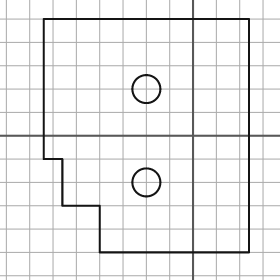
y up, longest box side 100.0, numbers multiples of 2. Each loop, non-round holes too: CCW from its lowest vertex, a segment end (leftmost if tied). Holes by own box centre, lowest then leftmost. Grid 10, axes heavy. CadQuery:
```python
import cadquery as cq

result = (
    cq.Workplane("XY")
    .moveTo(-40.0, -50.0)
    .lineTo(24.0, -50.0)
    .lineTo(24.0, 50.0)
    .lineTo(-64.0, 50.0)
    .lineTo(-64.0, -10.0)
    .lineTo(-56.0, -10.0)
    .lineTo(-56.0, -30.0)
    .lineTo(-40.0, -30.0)
    .close()
    .moveTo(-20.0, -20.0)
    .circle(6.0)
    .moveTo(-20.0, 20.0)
    .circle(6.0)
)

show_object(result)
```